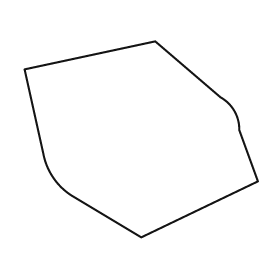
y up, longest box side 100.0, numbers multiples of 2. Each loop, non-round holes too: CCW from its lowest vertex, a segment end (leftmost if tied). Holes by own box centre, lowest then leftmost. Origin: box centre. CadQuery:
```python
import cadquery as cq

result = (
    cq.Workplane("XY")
    .moveTo(0.0, -42.0)
    .lineTo(50.0, -18.0)
    .lineTo(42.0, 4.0)
    .threePointArc((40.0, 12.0), (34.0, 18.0))
    .lineTo(6.0, 42.0)
    .lineTo(-50.0, 30.0)
    .lineTo(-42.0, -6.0)
    .threePointArc((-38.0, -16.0), (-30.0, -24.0))
    .close()
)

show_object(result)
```